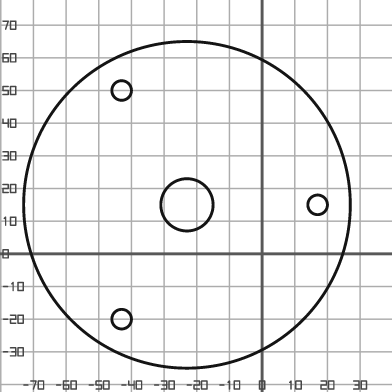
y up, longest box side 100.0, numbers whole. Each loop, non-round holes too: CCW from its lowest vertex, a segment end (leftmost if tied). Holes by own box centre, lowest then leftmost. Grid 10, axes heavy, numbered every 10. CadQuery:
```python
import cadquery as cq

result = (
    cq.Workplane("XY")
    .moveTo(-23.0, 15.0)
    .circle(50.0)
    .moveTo(-43.0, -20.0)
    .circle(3.0)
    .moveTo(-23.0, 15.0)
    .circle(8.0)
    .moveTo(17.0, 15.0)
    .circle(3.0)
    .moveTo(-43.0, 50.0)
    .circle(3.0)
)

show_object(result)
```